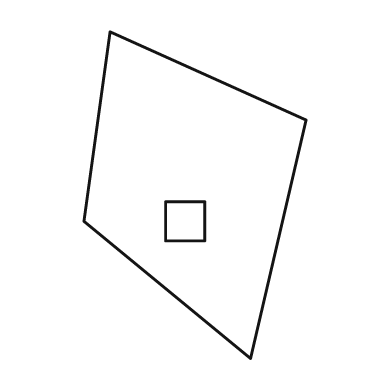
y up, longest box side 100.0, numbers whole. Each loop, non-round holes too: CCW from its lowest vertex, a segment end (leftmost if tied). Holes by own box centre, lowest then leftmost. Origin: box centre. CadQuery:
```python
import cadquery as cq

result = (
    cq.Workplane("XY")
    .moveTo(17.0, -50.0)
    .lineTo(34.0, 23.0)
    .lineTo(-26.0, 50.0)
    .lineTo(-34.0, -8.0)
    .close()
    .moveTo(-9.0, -14.0)
    .lineTo(3.0, -14.0)
    .lineTo(3.0, -2.0)
    .lineTo(-9.0, -2.0)
    .close()
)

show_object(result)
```